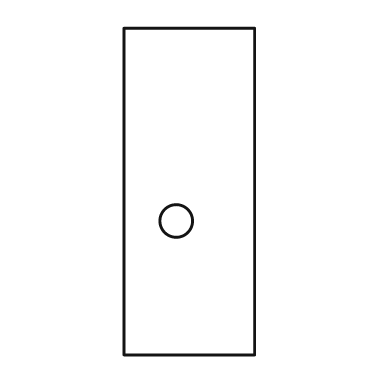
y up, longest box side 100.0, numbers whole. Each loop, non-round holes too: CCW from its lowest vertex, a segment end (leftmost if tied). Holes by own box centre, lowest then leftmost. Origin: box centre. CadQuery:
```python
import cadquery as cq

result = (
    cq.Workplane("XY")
    .moveTo(-20.0, -50.0)
    .lineTo(20.0, -50.0)
    .lineTo(20.0, 50.0)
    .lineTo(-20.0, 50.0)
    .close()
    .moveTo(-4.0, -9.0)
    .circle(5.0)
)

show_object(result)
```